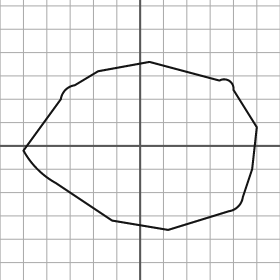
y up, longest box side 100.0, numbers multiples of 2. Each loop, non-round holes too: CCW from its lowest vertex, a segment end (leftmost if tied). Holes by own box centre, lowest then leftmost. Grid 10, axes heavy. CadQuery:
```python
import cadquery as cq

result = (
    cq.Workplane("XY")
    .moveTo(12.0, -36.0)
    .lineTo(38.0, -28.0)
    .threePointArc((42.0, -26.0), (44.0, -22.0))
    .lineTo(48.0, -10.0)
    .lineTo(50.0, 8.0)
    .lineTo(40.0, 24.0)
    .threePointArc((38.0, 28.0), (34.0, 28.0))
    .lineTo(4.0, 36.0)
    .lineTo(-18.0, 32.0)
    .lineTo(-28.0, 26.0)
    .threePointArc((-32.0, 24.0), (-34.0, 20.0))
    .lineTo(-50.0, -2.0)
    .threePointArc((-44.0, -10.0), (-36.0, -16.0))
    .lineTo(-12.0, -32.0)
    .close()
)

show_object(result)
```